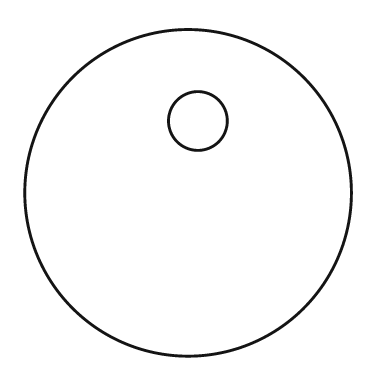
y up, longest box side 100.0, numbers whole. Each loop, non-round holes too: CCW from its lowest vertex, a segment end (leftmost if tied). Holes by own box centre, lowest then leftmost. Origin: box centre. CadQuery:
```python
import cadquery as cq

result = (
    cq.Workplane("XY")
    .moveTo(0.0, 0.0)
    .circle(50.0)
    .moveTo(3.0, 22.0)
    .circle(9.0)
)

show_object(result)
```